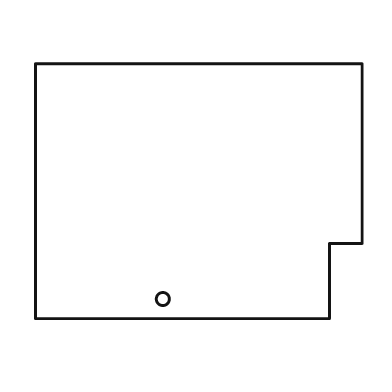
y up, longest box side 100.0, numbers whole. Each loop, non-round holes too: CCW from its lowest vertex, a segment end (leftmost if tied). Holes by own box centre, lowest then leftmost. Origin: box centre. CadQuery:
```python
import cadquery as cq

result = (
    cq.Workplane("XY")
    .moveTo(-50.0, -39.0)
    .lineTo(40.0, -39.0)
    .lineTo(40.0, -16.0)
    .lineTo(50.0, -16.0)
    .lineTo(50.0, 39.0)
    .lineTo(-50.0, 39.0)
    .close()
    .moveTo(-11.0, -33.0)
    .circle(2.0)
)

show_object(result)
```